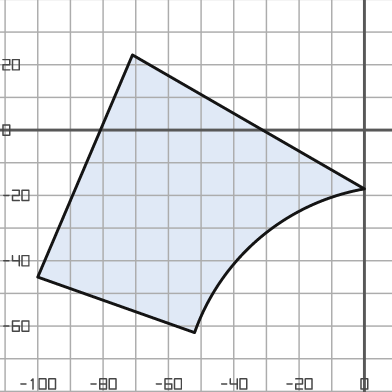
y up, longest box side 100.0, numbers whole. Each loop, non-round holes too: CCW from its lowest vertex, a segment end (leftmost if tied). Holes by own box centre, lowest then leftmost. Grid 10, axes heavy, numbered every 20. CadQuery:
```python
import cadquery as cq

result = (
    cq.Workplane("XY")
    .moveTo(-52.0, -62.0)
    .threePointArc((-32.0, -33.0), (0.0, -18.0))
    .lineTo(-71.0, 23.0)
    .lineTo(-100.0, -45.0)
    .close()
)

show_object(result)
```